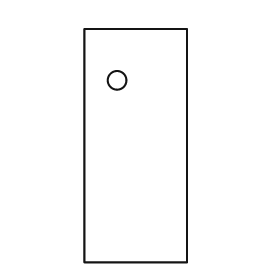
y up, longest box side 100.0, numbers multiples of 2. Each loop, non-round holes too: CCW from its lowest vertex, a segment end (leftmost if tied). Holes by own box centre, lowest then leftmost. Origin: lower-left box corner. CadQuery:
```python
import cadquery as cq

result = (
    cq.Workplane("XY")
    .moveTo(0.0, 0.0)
    .lineTo(44.0, 0.0)
    .lineTo(44.0, 100.0)
    .lineTo(0.0, 100.0)
    .close()
    .moveTo(14.0, 78.0)
    .circle(4.0)
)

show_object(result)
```